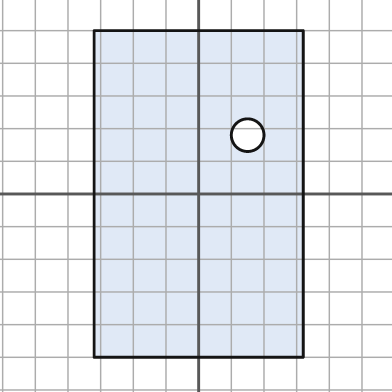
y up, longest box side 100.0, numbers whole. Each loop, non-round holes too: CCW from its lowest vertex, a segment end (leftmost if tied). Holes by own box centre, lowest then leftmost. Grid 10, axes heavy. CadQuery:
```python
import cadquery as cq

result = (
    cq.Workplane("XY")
    .moveTo(-32.0, -50.0)
    .lineTo(32.0, -50.0)
    .lineTo(32.0, 50.0)
    .lineTo(-32.0, 50.0)
    .close()
    .moveTo(15.0, 18.0)
    .circle(5.0)
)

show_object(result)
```